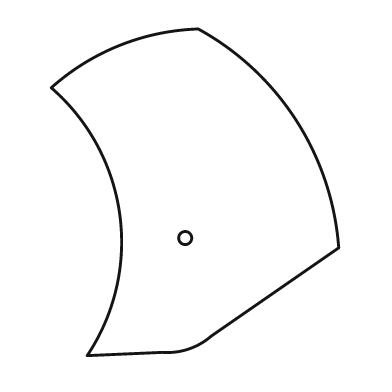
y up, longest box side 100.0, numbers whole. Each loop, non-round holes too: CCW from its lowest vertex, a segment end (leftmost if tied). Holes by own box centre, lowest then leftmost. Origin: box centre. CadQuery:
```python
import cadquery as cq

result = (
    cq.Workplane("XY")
    .moveTo(-33.0, -50.0)
    .lineTo(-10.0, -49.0)
    .threePointArc((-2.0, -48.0), (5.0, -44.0))
    .lineTo(44.0, -17.0)
    .threePointArc((31.0, 22.0), (1.0, 50.0))
    .threePointArc((-23.0, 45.0), (-44.0, 32.0))
    .threePointArc((-23.0, -7.0), (-33.0, -50.0))
    .close()
    .moveTo(-3.0, -14.0)
    .circle(2.0)
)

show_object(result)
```